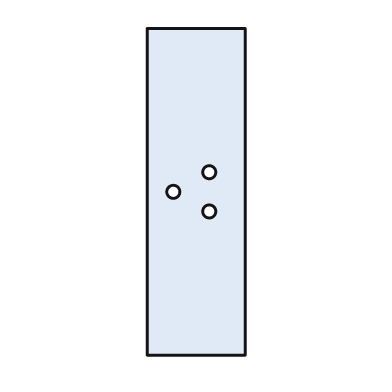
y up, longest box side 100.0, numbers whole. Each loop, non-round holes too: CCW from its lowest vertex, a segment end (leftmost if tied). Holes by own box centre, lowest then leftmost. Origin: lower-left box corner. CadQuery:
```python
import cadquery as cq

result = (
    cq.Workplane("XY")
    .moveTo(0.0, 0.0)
    .lineTo(30.0, 0.0)
    .lineTo(30.0, 100.0)
    .lineTo(0.0, 100.0)
    .close()
    .moveTo(19.0, 44.0)
    .circle(2.0)
    .moveTo(8.0, 50.0)
    .circle(2.0)
    .moveTo(19.0, 56.0)
    .circle(2.0)
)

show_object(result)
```